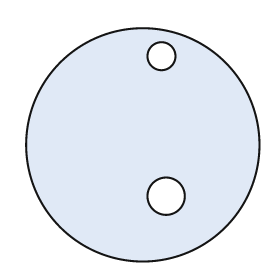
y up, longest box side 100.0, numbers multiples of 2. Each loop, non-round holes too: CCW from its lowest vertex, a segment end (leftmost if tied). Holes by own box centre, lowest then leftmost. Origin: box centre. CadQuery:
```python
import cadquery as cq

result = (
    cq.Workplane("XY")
    .moveTo(0.0, 0.0)
    .circle(50.0)
    .moveTo(10.0, -22.0)
    .circle(8.0)
    .moveTo(8.0, 38.0)
    .circle(6.0)
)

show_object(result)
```